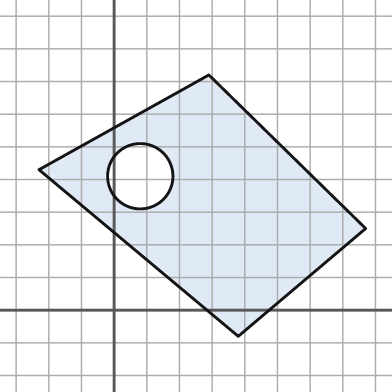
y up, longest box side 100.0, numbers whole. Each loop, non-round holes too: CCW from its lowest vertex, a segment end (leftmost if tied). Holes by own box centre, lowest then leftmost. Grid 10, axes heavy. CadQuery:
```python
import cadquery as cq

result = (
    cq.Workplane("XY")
    .moveTo(38.0, -8.0)
    .lineTo(77.0, 25.0)
    .lineTo(29.0, 72.0)
    .lineTo(-23.0, 43.0)
    .close()
    .moveTo(8.0, 41.0)
    .circle(10.0)
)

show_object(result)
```